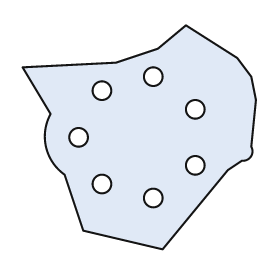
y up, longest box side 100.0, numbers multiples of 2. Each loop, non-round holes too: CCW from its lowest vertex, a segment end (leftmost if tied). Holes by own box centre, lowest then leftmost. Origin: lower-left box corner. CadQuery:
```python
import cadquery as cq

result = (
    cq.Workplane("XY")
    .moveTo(60.0, 0.0)
    .lineTo(88.0, 34.0)
    .lineTo(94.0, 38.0)
    .threePointArc((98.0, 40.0), (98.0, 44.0))
    .lineTo(100.0, 64.0)
    .lineTo(98.0, 74.0)
    .lineTo(92.0, 82.0)
    .lineTo(70.0, 96.0)
    .lineTo(58.0, 86.0)
    .lineTo(40.0, 80.0)
    .lineTo(0.0, 78.0)
    .lineTo(12.0, 58.0)
    .threePointArc((10.0, 44.0), (18.0, 32.0))
    .lineTo(26.0, 8.0)
    .close()
    .moveTo(56.0, 22.0)
    .circle(4.0)
    .moveTo(34.0, 28.0)
    .circle(4.0)
    .moveTo(74.0, 36.0)
    .circle(4.0)
    .moveTo(24.0, 48.0)
    .circle(4.0)
    .moveTo(74.0, 60.0)
    .circle(4.0)
    .moveTo(34.0, 68.0)
    .circle(4.0)
    .moveTo(56.0, 74.0)
    .circle(4.0)
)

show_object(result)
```